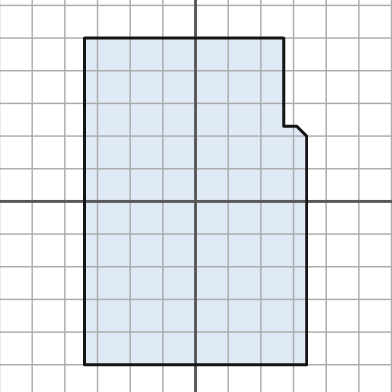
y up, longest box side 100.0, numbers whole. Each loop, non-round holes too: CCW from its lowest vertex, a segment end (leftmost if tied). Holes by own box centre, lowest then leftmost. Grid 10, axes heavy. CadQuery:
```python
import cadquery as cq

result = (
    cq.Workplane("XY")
    .moveTo(-34.0, -50.0)
    .lineTo(34.0, -50.0)
    .lineTo(34.0, 20.0)
    .lineTo(31.0, 23.0)
    .lineTo(27.0, 23.0)
    .lineTo(27.0, 50.0)
    .lineTo(-34.0, 50.0)
    .close()
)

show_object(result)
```